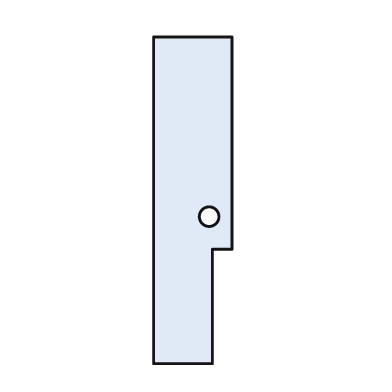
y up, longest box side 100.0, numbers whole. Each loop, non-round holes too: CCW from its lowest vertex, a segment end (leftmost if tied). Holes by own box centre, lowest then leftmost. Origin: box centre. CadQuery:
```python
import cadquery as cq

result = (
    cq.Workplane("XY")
    .moveTo(-12.0, -50.0)
    .lineTo(6.0, -50.0)
    .lineTo(6.0, -15.0)
    .lineTo(12.0, -15.0)
    .lineTo(12.0, 50.0)
    .lineTo(-12.0, 50.0)
    .close()
    .moveTo(5.0, -5.0)
    .circle(3.0)
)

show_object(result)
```